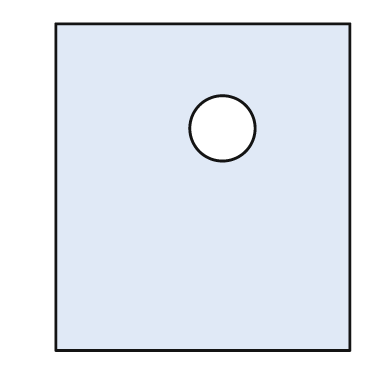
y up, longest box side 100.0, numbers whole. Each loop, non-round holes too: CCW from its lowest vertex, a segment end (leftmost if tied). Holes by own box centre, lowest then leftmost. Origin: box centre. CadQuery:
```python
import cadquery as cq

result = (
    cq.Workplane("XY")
    .moveTo(-45.0, -50.0)
    .lineTo(45.0, -50.0)
    .lineTo(45.0, 50.0)
    .lineTo(-45.0, 50.0)
    .close()
    .moveTo(6.0, 18.0)
    .circle(10.0)
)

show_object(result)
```